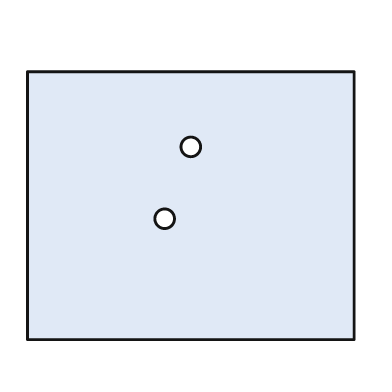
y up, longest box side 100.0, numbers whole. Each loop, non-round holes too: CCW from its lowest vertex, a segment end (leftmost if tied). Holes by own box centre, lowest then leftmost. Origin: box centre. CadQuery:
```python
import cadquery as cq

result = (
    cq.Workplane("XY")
    .moveTo(-50.0, -41.0)
    .lineTo(50.0, -41.0)
    .lineTo(50.0, 41.0)
    .lineTo(-50.0, 41.0)
    .close()
    .moveTo(-8.0, -4.0)
    .circle(3.0)
    .moveTo(0.0, 18.0)
    .circle(3.0)
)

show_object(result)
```